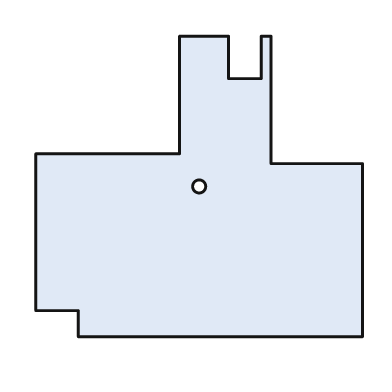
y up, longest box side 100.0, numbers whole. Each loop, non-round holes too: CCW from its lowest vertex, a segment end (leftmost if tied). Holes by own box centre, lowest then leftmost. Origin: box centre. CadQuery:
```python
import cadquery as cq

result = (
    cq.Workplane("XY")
    .moveTo(-37.0, -46.0)
    .lineTo(50.0, -46.0)
    .lineTo(50.0, 7.0)
    .lineTo(22.0, 7.0)
    .lineTo(22.0, 46.0)
    .lineTo(19.0, 46.0)
    .lineTo(19.0, 33.0)
    .lineTo(9.0, 33.0)
    .lineTo(9.0, 46.0)
    .lineTo(-6.0, 46.0)
    .lineTo(-6.0, 10.0)
    .lineTo(-50.0, 10.0)
    .lineTo(-50.0, -38.0)
    .lineTo(-37.0, -38.0)
    .close()
    .moveTo(0.0, 0.0)
    .circle(2.0)
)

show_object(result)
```